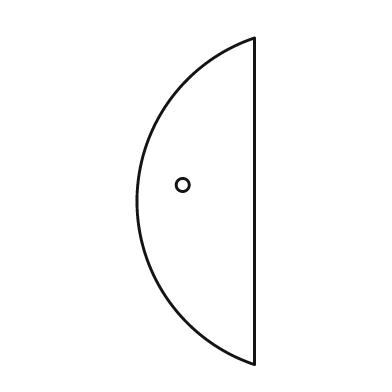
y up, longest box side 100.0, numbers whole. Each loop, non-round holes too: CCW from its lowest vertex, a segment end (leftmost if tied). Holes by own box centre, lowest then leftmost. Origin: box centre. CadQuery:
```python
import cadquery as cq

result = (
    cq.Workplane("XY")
    .moveTo(18.0, -50.0)
    .lineTo(18.0, 50.0)
    .threePointArc((-18.0, 0.0), (18.0, -50.0))
    .close()
    .moveTo(-4.0, 5.0)
    .circle(2.0)
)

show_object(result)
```